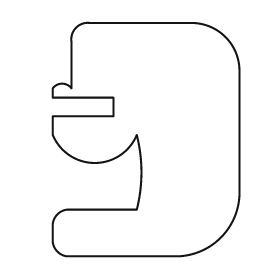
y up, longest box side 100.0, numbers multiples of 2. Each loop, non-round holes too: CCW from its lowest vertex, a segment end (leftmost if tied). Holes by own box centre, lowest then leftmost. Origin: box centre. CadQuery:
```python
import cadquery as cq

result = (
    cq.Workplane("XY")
    .moveTo(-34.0, -50.0)
    .lineTo(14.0, -50.0)
    .threePointArc((32.0, -42.0), (40.0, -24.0))
    .lineTo(40.0, 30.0)
    .threePointArc((34.0, 44.0), (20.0, 50.0))
    .lineTo(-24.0, 50.0)
    .threePointArc((-30.0, 48.0), (-32.0, 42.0))
    .lineTo(-32.0, 22.0)
    .threePointArc((-36.0, 24.0), (-40.0, 22.0))
    .lineTo(-40.0, 18.0)
    .lineTo(-14.0, 18.0)
    .lineTo(-14.0, 10.0)
    .lineTo(-40.0, 10.0)
    .lineTo(-40.0, 2.0)
    .threePointArc((-22.0, -10.0), (-4.0, 2.0))
    .threePointArc((-2.0, -14.0), (-4.0, -30.0))
    .lineTo(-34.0, -30.0)
    .threePointArc((-38.0, -32.0), (-40.0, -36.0))
    .lineTo(-40.0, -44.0)
    .threePointArc((-38.0, -48.0), (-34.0, -50.0))
    .close()
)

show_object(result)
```